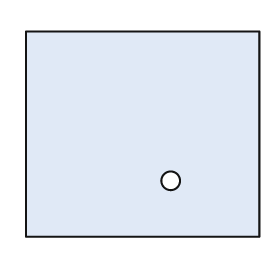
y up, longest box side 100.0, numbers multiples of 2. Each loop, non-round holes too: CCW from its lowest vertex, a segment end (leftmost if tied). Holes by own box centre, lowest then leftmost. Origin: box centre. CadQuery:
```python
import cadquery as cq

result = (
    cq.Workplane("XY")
    .moveTo(-50.0, -44.0)
    .lineTo(50.0, -44.0)
    .lineTo(50.0, 44.0)
    .lineTo(-50.0, 44.0)
    .close()
    .moveTo(12.0, -20.0)
    .circle(4.0)
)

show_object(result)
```